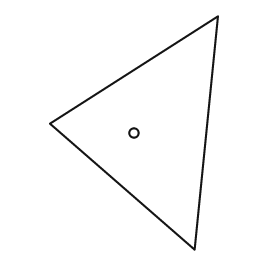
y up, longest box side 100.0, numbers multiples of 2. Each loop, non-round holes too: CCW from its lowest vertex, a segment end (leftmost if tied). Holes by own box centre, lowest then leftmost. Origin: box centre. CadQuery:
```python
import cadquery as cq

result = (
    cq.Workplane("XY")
    .moveTo(26.0, -50.0)
    .lineTo(36.0, 50.0)
    .lineTo(-36.0, 4.0)
    .close()
    .moveTo(0.0, 0.0)
    .circle(2.0)
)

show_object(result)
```